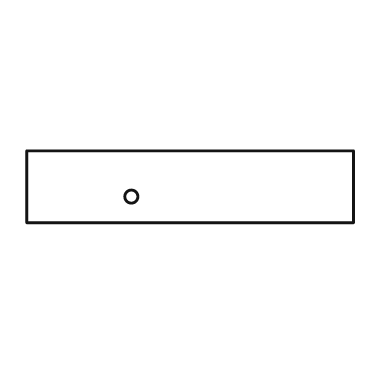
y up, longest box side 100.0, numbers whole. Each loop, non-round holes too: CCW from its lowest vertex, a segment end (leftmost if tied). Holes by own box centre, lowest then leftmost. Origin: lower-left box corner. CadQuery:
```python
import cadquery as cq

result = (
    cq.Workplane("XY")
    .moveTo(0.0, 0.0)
    .lineTo(100.0, 0.0)
    .lineTo(100.0, 22.0)
    .lineTo(0.0, 22.0)
    .close()
    .moveTo(32.0, 8.0)
    .circle(2.0)
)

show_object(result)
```